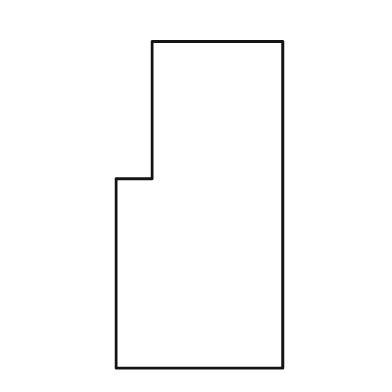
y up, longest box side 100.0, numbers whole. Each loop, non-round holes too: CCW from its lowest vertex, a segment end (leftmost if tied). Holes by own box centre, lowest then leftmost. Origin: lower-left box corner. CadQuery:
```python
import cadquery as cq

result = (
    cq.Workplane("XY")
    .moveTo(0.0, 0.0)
    .lineTo(51.0, 0.0)
    .lineTo(51.0, 100.0)
    .lineTo(11.0, 100.0)
    .lineTo(11.0, 58.0)
    .lineTo(0.0, 58.0)
    .close()
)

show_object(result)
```